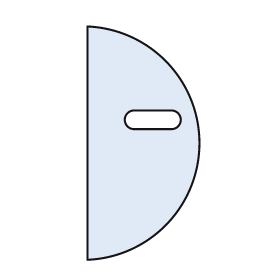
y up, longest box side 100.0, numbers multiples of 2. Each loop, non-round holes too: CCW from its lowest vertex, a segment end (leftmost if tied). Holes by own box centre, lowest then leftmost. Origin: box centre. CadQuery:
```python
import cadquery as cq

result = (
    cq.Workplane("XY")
    .moveTo(-24.0, -50.0)
    .threePointArc((24.0, 0.0), (-24.0, 50.0))
    .close()
    .moveTo(-4.0, 6.0)
    .lineTo(12.0, 6.0)
    .threePointArc((16.0, 10.0), (12.0, 14.0))
    .lineTo(-4.0, 14.0)
    .threePointArc((-8.0, 10.0), (-4.0, 6.0))
    .close()
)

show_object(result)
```